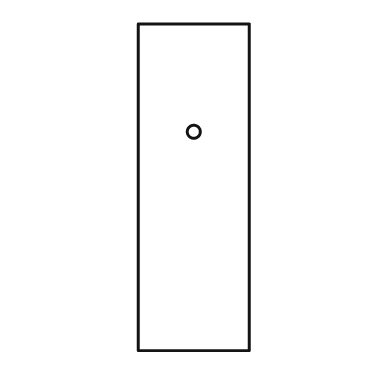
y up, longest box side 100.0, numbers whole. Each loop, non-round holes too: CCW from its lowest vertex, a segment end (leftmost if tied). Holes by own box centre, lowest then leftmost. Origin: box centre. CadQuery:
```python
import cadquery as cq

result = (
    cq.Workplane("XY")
    .moveTo(-17.0, -50.0)
    .lineTo(17.0, -50.0)
    .lineTo(17.0, 50.0)
    .lineTo(-17.0, 50.0)
    .close()
    .moveTo(0.0, 17.0)
    .circle(2.0)
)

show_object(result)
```